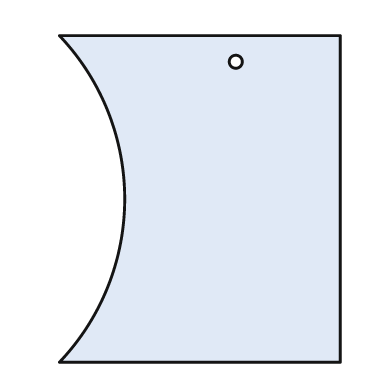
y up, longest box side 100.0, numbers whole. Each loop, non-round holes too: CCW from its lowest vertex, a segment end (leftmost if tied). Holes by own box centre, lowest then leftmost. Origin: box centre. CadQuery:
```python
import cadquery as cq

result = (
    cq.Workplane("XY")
    .moveTo(-43.0, -50.0)
    .lineTo(43.0, -50.0)
    .lineTo(43.0, 50.0)
    .lineTo(-43.0, 50.0)
    .threePointArc((-23.0, 0.0), (-43.0, -50.0))
    .close()
    .moveTo(11.0, 42.0)
    .circle(2.0)
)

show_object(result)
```